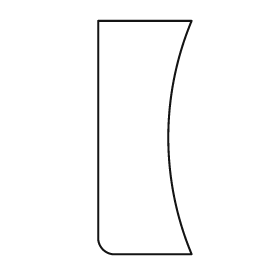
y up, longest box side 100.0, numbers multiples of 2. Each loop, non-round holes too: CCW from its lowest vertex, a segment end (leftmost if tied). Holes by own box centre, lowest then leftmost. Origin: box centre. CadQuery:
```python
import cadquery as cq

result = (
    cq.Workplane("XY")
    .moveTo(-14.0, -50.0)
    .lineTo(20.0, -50.0)
    .threePointArc((10.0, 0.0), (20.0, 50.0))
    .lineTo(-20.0, 50.0)
    .lineTo(-20.0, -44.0)
    .threePointArc((-18.0, -48.0), (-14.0, -50.0))
    .close()
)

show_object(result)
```